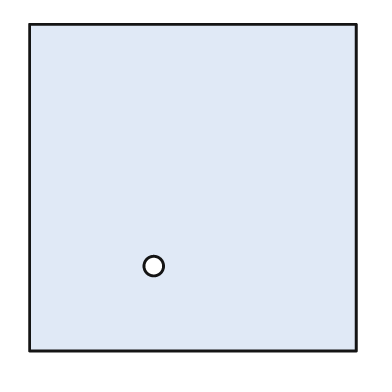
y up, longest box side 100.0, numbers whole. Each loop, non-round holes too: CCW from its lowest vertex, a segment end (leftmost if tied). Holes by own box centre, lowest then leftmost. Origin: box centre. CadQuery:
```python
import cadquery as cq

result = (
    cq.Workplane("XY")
    .moveTo(-50.0, -50.0)
    .lineTo(50.0, -50.0)
    .lineTo(50.0, 50.0)
    .lineTo(-50.0, 50.0)
    .close()
    .moveTo(-12.0, -24.0)
    .circle(3.0)
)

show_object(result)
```